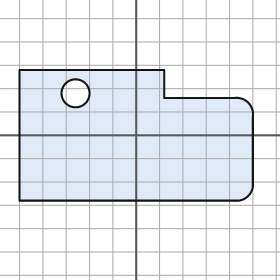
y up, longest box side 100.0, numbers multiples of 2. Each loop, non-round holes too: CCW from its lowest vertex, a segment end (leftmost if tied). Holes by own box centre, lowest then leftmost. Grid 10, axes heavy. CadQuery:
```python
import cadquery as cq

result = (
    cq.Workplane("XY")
    .moveTo(-50.0, -28.0)
    .lineTo(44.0, -28.0)
    .threePointArc((48.0, -26.0), (50.0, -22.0))
    .lineTo(50.0, 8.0)
    .threePointArc((48.0, 14.0), (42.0, 16.0))
    .lineTo(12.0, 16.0)
    .lineTo(12.0, 28.0)
    .lineTo(-50.0, 28.0)
    .close()
    .moveTo(-26.0, 18.0)
    .circle(6.0)
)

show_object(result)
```